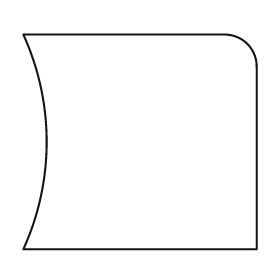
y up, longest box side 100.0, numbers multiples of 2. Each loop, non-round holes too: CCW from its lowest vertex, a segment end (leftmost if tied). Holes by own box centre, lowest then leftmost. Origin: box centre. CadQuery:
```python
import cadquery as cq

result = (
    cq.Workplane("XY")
    .moveTo(-50.0, -46.0)
    .lineTo(50.0, -46.0)
    .lineTo(50.0, 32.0)
    .threePointArc((46.0, 42.0), (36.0, 46.0))
    .lineTo(-50.0, 46.0)
    .threePointArc((-40.0, 0.0), (-50.0, -46.0))
    .close()
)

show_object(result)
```